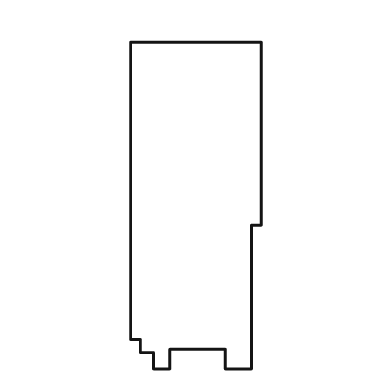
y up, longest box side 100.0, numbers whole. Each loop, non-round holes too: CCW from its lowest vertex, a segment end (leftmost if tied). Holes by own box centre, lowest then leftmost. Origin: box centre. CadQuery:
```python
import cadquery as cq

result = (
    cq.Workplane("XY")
    .moveTo(-13.0, -50.0)
    .lineTo(-8.0, -50.0)
    .lineTo(-8.0, -44.0)
    .lineTo(9.0, -44.0)
    .lineTo(9.0, -50.0)
    .lineTo(17.0, -50.0)
    .lineTo(17.0, -6.0)
    .lineTo(20.0, -6.0)
    .lineTo(20.0, 50.0)
    .lineTo(-20.0, 50.0)
    .lineTo(-20.0, -41.0)
    .lineTo(-17.0, -41.0)
    .lineTo(-17.0, -45.0)
    .lineTo(-13.0, -45.0)
    .close()
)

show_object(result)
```